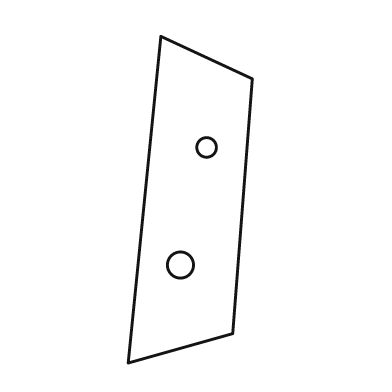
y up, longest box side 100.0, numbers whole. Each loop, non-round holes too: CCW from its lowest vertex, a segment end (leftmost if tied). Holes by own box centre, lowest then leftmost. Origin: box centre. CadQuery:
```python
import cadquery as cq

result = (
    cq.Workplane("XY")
    .moveTo(-19.0, -50.0)
    .lineTo(13.0, -41.0)
    .lineTo(19.0, 37.0)
    .lineTo(-9.0, 50.0)
    .close()
    .moveTo(-3.0, -20.0)
    .circle(4.0)
    .moveTo(5.0, 16.0)
    .circle(3.0)
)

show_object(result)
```